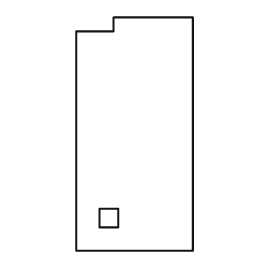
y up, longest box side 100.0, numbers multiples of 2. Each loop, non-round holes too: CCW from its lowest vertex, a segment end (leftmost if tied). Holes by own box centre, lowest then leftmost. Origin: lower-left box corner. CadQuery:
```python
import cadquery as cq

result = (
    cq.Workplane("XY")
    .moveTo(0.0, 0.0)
    .lineTo(50.0, 0.0)
    .lineTo(50.0, 100.0)
    .lineTo(16.0, 100.0)
    .lineTo(16.0, 94.0)
    .lineTo(0.0, 94.0)
    .close()
    .moveTo(10.0, 10.0)
    .lineTo(18.0, 10.0)
    .lineTo(18.0, 18.0)
    .lineTo(10.0, 18.0)
    .close()
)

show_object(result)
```